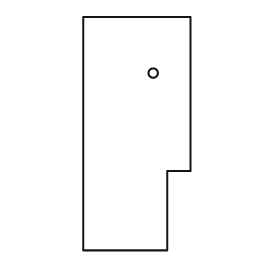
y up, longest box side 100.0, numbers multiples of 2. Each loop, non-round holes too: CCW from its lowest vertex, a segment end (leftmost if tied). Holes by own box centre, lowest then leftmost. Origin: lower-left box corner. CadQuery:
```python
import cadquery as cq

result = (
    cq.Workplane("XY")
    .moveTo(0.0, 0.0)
    .lineTo(36.0, 0.0)
    .lineTo(36.0, 34.0)
    .lineTo(46.0, 34.0)
    .lineTo(46.0, 100.0)
    .lineTo(0.0, 100.0)
    .close()
    .moveTo(30.0, 76.0)
    .circle(2.0)
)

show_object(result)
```